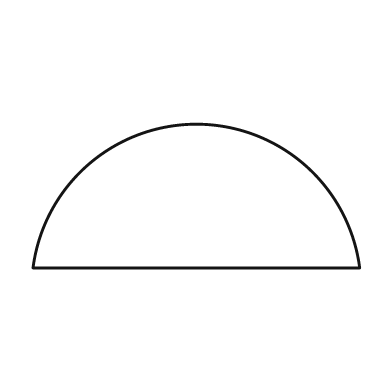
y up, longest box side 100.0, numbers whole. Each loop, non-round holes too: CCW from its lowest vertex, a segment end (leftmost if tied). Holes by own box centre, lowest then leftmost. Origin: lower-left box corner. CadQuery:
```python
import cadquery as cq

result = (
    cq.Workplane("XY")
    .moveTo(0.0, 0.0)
    .lineTo(100.0, 0.0)
    .threePointArc((50.0, 44.0), (0.0, 0.0))
    .close()
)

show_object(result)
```